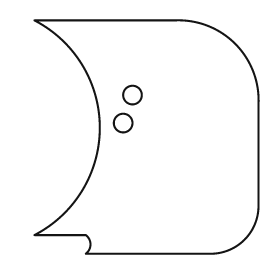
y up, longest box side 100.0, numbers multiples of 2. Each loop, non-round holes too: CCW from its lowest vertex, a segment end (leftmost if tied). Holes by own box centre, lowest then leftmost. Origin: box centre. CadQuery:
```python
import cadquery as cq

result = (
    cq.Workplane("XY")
    .moveTo(-26.0, -50.0)
    .lineTo(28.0, -50.0)
    .threePointArc((42.0, -44.0), (48.0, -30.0))
    .lineTo(48.0, 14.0)
    .threePointArc((38.0, 40.0), (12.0, 50.0))
    .lineTo(-48.0, 50.0)
    .threePointArc((-20.0, 4.0), (-48.0, -42.0))
    .lineTo(-26.0, -42.0)
    .threePointArc((-24.0, -46.0), (-26.0, -50.0))
    .close()
    .moveTo(-10.0, 6.0)
    .circle(4.0)
    .moveTo(-6.0, 18.0)
    .circle(4.0)
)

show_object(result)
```